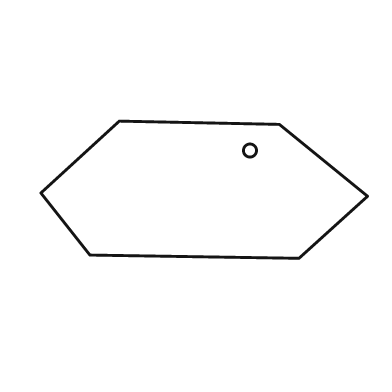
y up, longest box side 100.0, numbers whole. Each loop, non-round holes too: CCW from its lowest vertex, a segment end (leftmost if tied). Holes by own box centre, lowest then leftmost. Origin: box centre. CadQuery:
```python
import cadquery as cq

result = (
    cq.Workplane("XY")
    .moveTo(29.0, -21.0)
    .lineTo(50.0, -2.0)
    .lineTo(23.0, 20.0)
    .lineTo(-26.0, 21.0)
    .lineTo(-50.0, -1.0)
    .lineTo(-35.0, -20.0)
    .close()
    .moveTo(14.0, 12.0)
    .circle(2.0)
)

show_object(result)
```